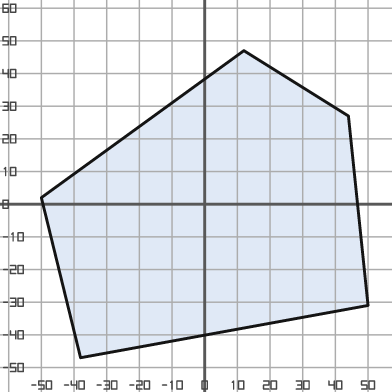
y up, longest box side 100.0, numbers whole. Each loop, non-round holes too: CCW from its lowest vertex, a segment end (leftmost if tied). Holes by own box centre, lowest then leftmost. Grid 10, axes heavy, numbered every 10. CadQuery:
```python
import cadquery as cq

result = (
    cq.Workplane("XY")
    .moveTo(-38.0, -47.0)
    .lineTo(50.0, -31.0)
    .lineTo(44.0, 27.0)
    .lineTo(12.0, 47.0)
    .lineTo(-50.0, 2.0)
    .close()
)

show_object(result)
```